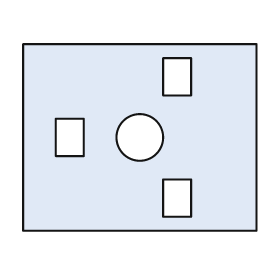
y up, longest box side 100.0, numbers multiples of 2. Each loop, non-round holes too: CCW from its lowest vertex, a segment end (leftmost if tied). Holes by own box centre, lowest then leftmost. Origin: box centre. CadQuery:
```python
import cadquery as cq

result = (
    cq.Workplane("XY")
    .moveTo(-50.0, -40.0)
    .lineTo(50.0, -40.0)
    .lineTo(50.0, 40.0)
    .lineTo(-50.0, 40.0)
    .close()
    .moveTo(10.0, -34.0)
    .lineTo(22.0, -34.0)
    .lineTo(22.0, -18.0)
    .lineTo(10.0, -18.0)
    .close()
    .moveTo(-36.0, -8.0)
    .lineTo(-24.0, -8.0)
    .lineTo(-24.0, 8.0)
    .lineTo(-36.0, 8.0)
    .close()
    .moveTo(0.0, 0.0)
    .circle(10.0)
    .moveTo(10.0, 18.0)
    .lineTo(22.0, 18.0)
    .lineTo(22.0, 34.0)
    .lineTo(10.0, 34.0)
    .close()
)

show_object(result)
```